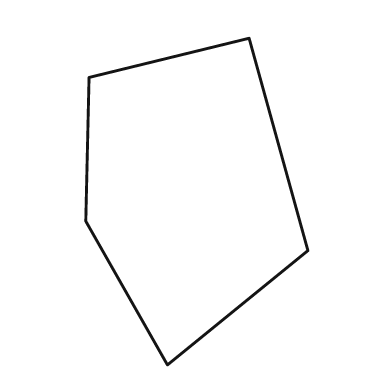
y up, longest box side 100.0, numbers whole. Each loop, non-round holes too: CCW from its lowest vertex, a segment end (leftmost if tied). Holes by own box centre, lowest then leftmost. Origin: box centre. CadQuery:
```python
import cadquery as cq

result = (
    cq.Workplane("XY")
    .moveTo(-9.0, -50.0)
    .lineTo(34.0, -15.0)
    .lineTo(16.0, 50.0)
    .lineTo(-33.0, 38.0)
    .lineTo(-34.0, -6.0)
    .close()
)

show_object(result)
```